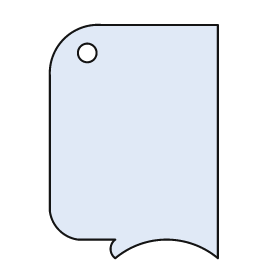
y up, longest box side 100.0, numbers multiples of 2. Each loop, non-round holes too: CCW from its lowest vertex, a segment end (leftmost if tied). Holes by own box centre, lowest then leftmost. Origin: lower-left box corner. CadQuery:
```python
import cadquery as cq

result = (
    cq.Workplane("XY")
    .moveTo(28.0, 0.0)
    .threePointArc((50.0, 8.0), (72.0, 0.0))
    .lineTo(72.0, 100.0)
    .lineTo(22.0, 100.0)
    .threePointArc((6.0, 94.0), (0.0, 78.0))
    .lineTo(0.0, 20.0)
    .threePointArc((4.0, 12.0), (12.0, 8.0))
    .lineTo(28.0, 8.0)
    .threePointArc((26.0, 4.0), (28.0, 0.0))
    .close()
    .moveTo(16.0, 88.0)
    .circle(4.0)
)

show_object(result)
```